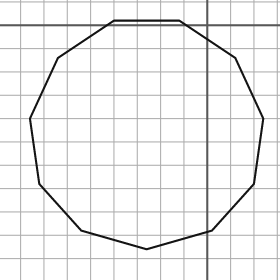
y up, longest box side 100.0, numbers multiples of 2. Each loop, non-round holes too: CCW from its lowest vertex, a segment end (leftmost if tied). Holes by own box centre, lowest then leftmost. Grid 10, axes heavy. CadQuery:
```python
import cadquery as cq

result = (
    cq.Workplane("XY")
    .moveTo(-26.0, -96.0)
    .lineTo(2.0, -88.0)
    .lineTo(20.0, -68.0)
    .lineTo(24.0, -40.0)
    .lineTo(12.0, -14.0)
    .lineTo(-12.0, 2.0)
    .lineTo(-40.0, 2.0)
    .lineTo(-64.0, -14.0)
    .lineTo(-76.0, -40.0)
    .lineTo(-72.0, -68.0)
    .lineTo(-54.0, -88.0)
    .close()
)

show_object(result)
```